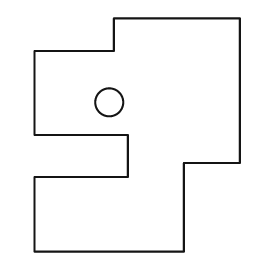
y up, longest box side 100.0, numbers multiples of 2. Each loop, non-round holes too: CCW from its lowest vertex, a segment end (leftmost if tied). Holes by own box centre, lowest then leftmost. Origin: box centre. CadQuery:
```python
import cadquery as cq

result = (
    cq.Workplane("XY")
    .moveTo(-44.0, -50.0)
    .lineTo(20.0, -50.0)
    .lineTo(20.0, -12.0)
    .lineTo(44.0, -12.0)
    .lineTo(44.0, 50.0)
    .lineTo(-10.0, 50.0)
    .lineTo(-10.0, 36.0)
    .lineTo(-44.0, 36.0)
    .lineTo(-44.0, 0.0)
    .lineTo(-4.0, 0.0)
    .lineTo(-4.0, -18.0)
    .lineTo(-44.0, -18.0)
    .close()
    .moveTo(-12.0, 14.0)
    .circle(6.0)
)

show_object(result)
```